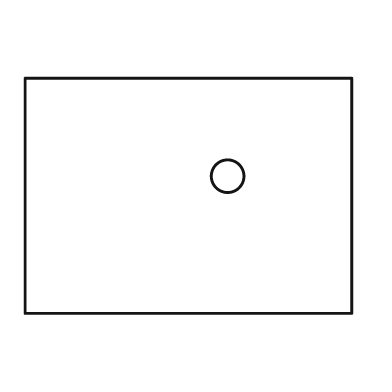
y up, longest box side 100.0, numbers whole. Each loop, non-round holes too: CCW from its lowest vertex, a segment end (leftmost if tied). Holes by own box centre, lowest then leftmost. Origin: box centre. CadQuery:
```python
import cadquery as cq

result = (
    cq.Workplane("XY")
    .moveTo(-50.0, -36.0)
    .lineTo(50.0, -36.0)
    .lineTo(50.0, 36.0)
    .lineTo(-50.0, 36.0)
    .close()
    .moveTo(12.0, 6.0)
    .circle(5.0)
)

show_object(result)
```